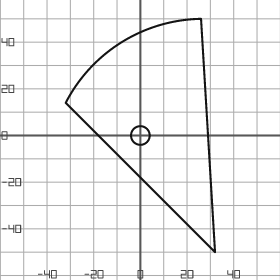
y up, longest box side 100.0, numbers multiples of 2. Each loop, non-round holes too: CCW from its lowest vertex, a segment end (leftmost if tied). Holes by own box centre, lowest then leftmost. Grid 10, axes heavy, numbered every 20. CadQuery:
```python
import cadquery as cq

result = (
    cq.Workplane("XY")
    .moveTo(32.0, -50.0)
    .lineTo(26.0, 50.0)
    .threePointArc((-8.0, 40.0), (-32.0, 14.0))
    .close()
    .moveTo(0.0, 0.0)
    .circle(4.0)
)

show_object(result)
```